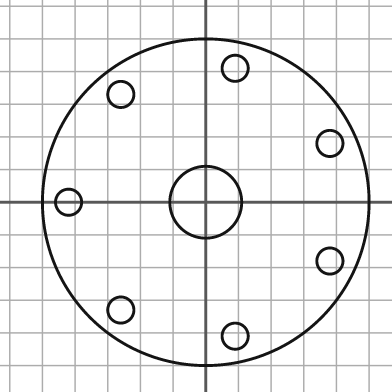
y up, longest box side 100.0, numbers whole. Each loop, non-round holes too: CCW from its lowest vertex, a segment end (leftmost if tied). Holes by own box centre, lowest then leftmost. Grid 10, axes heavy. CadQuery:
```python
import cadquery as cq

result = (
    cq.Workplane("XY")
    .moveTo(0.0, 0.0)
    .circle(50.0)
    .moveTo(9.0, -41.0)
    .circle(4.0)
    .moveTo(-26.0, -33.0)
    .circle(4.0)
    .moveTo(38.0, -18.0)
    .circle(4.0)
    .moveTo(-42.0, 0.0)
    .circle(4.0)
    .moveTo(0.0, 0.0)
    .circle(11.0)
    .moveTo(38.0, 18.0)
    .circle(4.0)
    .moveTo(-26.0, 33.0)
    .circle(4.0)
    .moveTo(9.0, 41.0)
    .circle(4.0)
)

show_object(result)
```